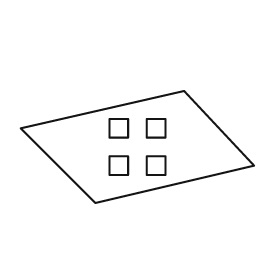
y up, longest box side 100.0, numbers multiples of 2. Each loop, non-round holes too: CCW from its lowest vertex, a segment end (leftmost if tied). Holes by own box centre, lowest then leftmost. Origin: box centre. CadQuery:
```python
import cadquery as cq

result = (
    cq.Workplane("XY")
    .moveTo(-18.0, -24.0)
    .lineTo(50.0, -8.0)
    .lineTo(20.0, 24.0)
    .lineTo(-50.0, 8.0)
    .close()
    .moveTo(-12.0, -12.0)
    .lineTo(-4.0, -12.0)
    .lineTo(-4.0, -4.0)
    .lineTo(-12.0, -4.0)
    .close()
    .moveTo(4.0, -12.0)
    .lineTo(12.0, -12.0)
    .lineTo(12.0, -4.0)
    .lineTo(4.0, -4.0)
    .close()
    .moveTo(-12.0, 4.0)
    .lineTo(-4.0, 4.0)
    .lineTo(-4.0, 12.0)
    .lineTo(-12.0, 12.0)
    .close()
    .moveTo(4.0, 4.0)
    .lineTo(12.0, 4.0)
    .lineTo(12.0, 12.0)
    .lineTo(4.0, 12.0)
    .close()
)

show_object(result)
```